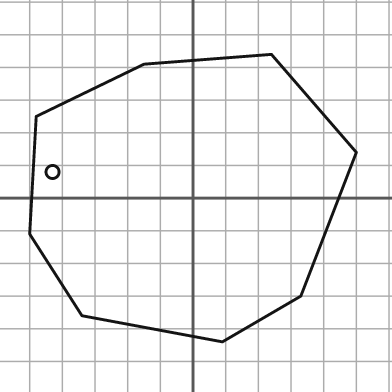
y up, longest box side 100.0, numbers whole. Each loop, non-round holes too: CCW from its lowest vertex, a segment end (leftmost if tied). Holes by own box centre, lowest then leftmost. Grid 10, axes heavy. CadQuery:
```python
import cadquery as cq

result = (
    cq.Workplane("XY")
    .moveTo(9.0, -44.0)
    .lineTo(33.0, -30.0)
    .lineTo(50.0, 14.0)
    .lineTo(24.0, 44.0)
    .lineTo(-15.0, 41.0)
    .lineTo(-48.0, 25.0)
    .lineTo(-50.0, -11.0)
    .lineTo(-34.0, -36.0)
    .close()
    .moveTo(-43.0, 8.0)
    .circle(2.0)
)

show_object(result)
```